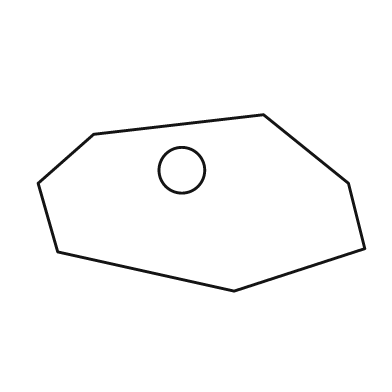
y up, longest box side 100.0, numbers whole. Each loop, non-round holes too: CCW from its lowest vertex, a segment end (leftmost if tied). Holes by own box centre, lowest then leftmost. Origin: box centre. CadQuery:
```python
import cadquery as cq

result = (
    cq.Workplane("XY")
    .moveTo(10.0, -27.0)
    .lineTo(50.0, -14.0)
    .lineTo(45.0, 6.0)
    .lineTo(19.0, 27.0)
    .lineTo(-33.0, 21.0)
    .lineTo(-50.0, 6.0)
    .lineTo(-44.0, -15.0)
    .close()
    .moveTo(-6.0, 10.0)
    .circle(7.0)
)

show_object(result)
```